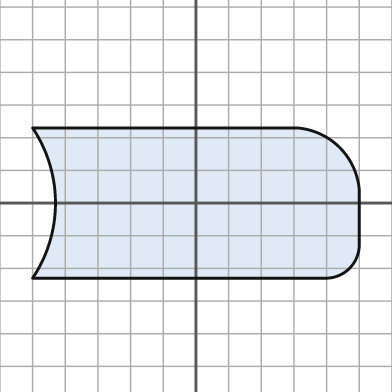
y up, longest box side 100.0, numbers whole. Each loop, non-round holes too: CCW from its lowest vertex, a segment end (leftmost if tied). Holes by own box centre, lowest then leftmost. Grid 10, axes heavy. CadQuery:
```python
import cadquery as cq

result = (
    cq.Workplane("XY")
    .moveTo(-50.0, -23.0)
    .lineTo(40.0, -23.0)
    .threePointArc((47.0, -20.0), (50.0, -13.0))
    .lineTo(50.0, 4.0)
    .threePointArc((44.0, 17.0), (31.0, 23.0))
    .lineTo(-50.0, 23.0)
    .threePointArc((-43.0, 0.0), (-50.0, -23.0))
    .close()
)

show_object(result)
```